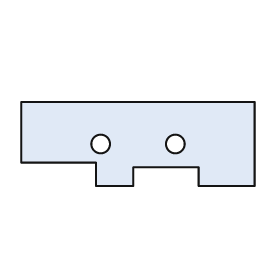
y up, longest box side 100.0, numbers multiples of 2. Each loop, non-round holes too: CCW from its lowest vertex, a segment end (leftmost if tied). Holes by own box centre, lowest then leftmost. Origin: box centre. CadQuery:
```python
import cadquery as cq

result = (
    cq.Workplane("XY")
    .moveTo(-18.0, -18.0)
    .lineTo(-2.0, -18.0)
    .lineTo(-2.0, -10.0)
    .lineTo(26.0, -10.0)
    .lineTo(26.0, -18.0)
    .lineTo(50.0, -18.0)
    .lineTo(50.0, 18.0)
    .lineTo(-50.0, 18.0)
    .lineTo(-50.0, -8.0)
    .lineTo(-18.0, -8.0)
    .close()
    .moveTo(-16.0, 0.0)
    .circle(4.0)
    .moveTo(16.0, 0.0)
    .circle(4.0)
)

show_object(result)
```